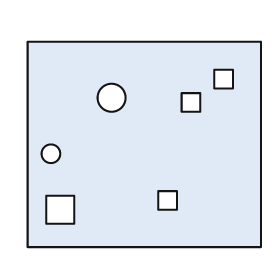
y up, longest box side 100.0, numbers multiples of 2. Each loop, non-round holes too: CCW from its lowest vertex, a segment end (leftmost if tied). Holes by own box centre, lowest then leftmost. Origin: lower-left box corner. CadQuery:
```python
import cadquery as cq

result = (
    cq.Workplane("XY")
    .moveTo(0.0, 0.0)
    .lineTo(100.0, 0.0)
    .lineTo(100.0, 88.0)
    .lineTo(0.0, 88.0)
    .close()
    .moveTo(8.0, 10.0)
    .lineTo(20.0, 10.0)
    .lineTo(20.0, 22.0)
    .lineTo(8.0, 22.0)
    .close()
    .moveTo(56.0, 16.0)
    .lineTo(64.0, 16.0)
    .lineTo(64.0, 24.0)
    .lineTo(56.0, 24.0)
    .close()
    .moveTo(10.0, 40.0)
    .circle(4.0)
    .moveTo(66.0, 58.0)
    .lineTo(74.0, 58.0)
    .lineTo(74.0, 66.0)
    .lineTo(66.0, 66.0)
    .close()
    .moveTo(36.0, 64.0)
    .circle(6.0)
    .moveTo(80.0, 68.0)
    .lineTo(88.0, 68.0)
    .lineTo(88.0, 76.0)
    .lineTo(80.0, 76.0)
    .close()
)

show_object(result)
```